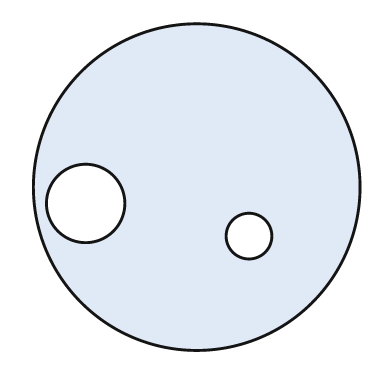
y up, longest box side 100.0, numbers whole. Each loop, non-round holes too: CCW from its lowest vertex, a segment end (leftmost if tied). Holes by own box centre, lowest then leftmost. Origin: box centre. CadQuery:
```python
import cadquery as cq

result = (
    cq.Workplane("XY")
    .moveTo(0.0, 0.0)
    .circle(50.0)
    .moveTo(16.0, -15.0)
    .circle(7.0)
    .moveTo(-34.0, -5.0)
    .circle(12.0)
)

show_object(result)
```